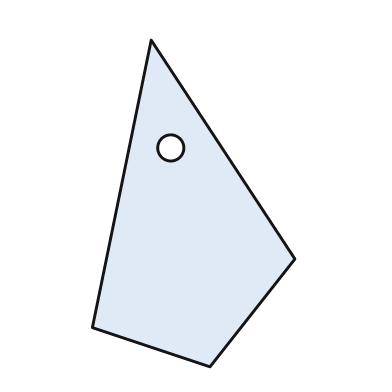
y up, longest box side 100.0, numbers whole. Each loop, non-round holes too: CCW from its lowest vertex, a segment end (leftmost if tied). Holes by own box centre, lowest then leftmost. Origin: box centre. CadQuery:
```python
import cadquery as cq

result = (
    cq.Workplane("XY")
    .moveTo(5.0, -50.0)
    .lineTo(31.0, -17.0)
    .lineTo(-13.0, 50.0)
    .lineTo(-31.0, -38.0)
    .close()
    .moveTo(-7.0, 17.0)
    .circle(4.0)
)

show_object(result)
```